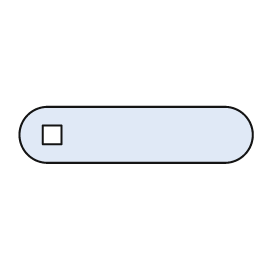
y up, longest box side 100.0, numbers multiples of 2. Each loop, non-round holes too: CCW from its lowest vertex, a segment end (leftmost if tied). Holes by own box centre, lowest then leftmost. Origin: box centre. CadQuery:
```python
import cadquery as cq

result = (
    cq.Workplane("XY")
    .moveTo(-38.0, -12.0)
    .lineTo(38.0, -12.0)
    .threePointArc((50.0, 0.0), (38.0, 12.0))
    .lineTo(-38.0, 12.0)
    .threePointArc((-50.0, 0.0), (-38.0, -12.0))
    .close()
    .moveTo(-40.0, -4.0)
    .lineTo(-32.0, -4.0)
    .lineTo(-32.0, 4.0)
    .lineTo(-40.0, 4.0)
    .close()
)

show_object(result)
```